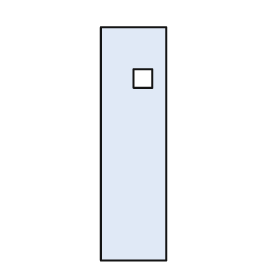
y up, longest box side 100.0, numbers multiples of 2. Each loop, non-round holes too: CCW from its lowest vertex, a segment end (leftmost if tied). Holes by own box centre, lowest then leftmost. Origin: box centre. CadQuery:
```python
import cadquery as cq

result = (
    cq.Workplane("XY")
    .moveTo(-14.0, -50.0)
    .lineTo(14.0, -50.0)
    .lineTo(14.0, 50.0)
    .lineTo(-14.0, 50.0)
    .close()
    .moveTo(0.0, 24.0)
    .lineTo(8.0, 24.0)
    .lineTo(8.0, 32.0)
    .lineTo(0.0, 32.0)
    .close()
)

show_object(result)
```